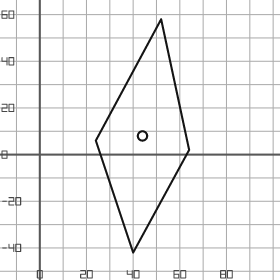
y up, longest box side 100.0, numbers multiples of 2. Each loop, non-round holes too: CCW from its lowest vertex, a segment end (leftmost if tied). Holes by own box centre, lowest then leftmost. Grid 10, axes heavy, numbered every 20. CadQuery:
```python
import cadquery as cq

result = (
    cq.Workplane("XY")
    .moveTo(40.0, -42.0)
    .lineTo(64.0, 2.0)
    .lineTo(52.0, 58.0)
    .lineTo(24.0, 6.0)
    .close()
    .moveTo(44.0, 8.0)
    .circle(2.0)
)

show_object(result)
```